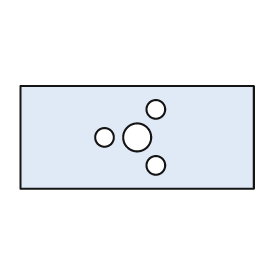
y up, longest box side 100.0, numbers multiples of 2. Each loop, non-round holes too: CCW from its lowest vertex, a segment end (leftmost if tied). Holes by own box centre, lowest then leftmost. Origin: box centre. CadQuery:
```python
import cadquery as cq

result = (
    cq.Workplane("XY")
    .moveTo(-50.0, -22.0)
    .lineTo(50.0, -22.0)
    .lineTo(50.0, 22.0)
    .lineTo(-50.0, 22.0)
    .close()
    .moveTo(8.0, -12.0)
    .circle(4.0)
    .moveTo(-14.0, 0.0)
    .circle(4.0)
    .moveTo(0.0, 0.0)
    .circle(6.0)
    .moveTo(8.0, 12.0)
    .circle(4.0)
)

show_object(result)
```